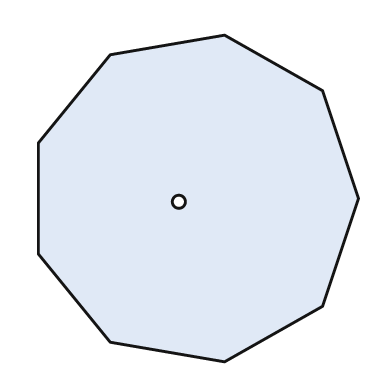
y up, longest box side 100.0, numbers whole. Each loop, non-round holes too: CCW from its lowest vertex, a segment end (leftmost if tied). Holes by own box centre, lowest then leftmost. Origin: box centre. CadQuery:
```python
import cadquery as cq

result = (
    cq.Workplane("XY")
    .moveTo(8.0, -50.0)
    .lineTo(38.0, -33.0)
    .lineTo(49.0, 0.0)
    .lineTo(38.0, 33.0)
    .lineTo(8.0, 50.0)
    .lineTo(-27.0, 44.0)
    .lineTo(-49.0, 17.0)
    .lineTo(-49.0, -17.0)
    .lineTo(-27.0, -44.0)
    .close()
    .moveTo(-6.0, -1.0)
    .circle(2.0)
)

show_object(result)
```